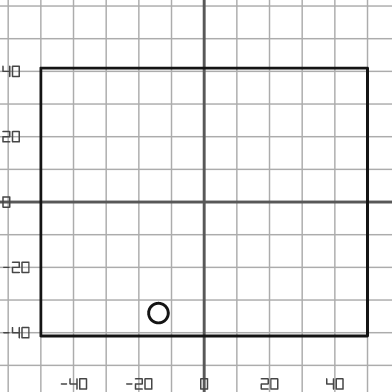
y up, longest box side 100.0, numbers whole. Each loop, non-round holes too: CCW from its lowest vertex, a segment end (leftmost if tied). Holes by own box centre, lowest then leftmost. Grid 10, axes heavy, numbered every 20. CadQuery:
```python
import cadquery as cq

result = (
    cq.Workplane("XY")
    .moveTo(-50.0, -41.0)
    .lineTo(50.0, -41.0)
    .lineTo(50.0, 41.0)
    .lineTo(-50.0, 41.0)
    .close()
    .moveTo(-14.0, -34.0)
    .circle(3.0)
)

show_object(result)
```